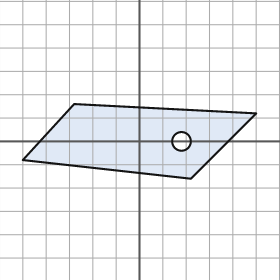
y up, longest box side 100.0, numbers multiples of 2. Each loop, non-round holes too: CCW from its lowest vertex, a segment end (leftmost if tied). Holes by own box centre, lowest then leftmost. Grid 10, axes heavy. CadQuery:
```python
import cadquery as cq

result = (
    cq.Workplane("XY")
    .moveTo(22.0, -16.0)
    .lineTo(50.0, 12.0)
    .lineTo(-28.0, 16.0)
    .lineTo(-50.0, -8.0)
    .close()
    .moveTo(18.0, 0.0)
    .circle(4.0)
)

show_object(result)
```